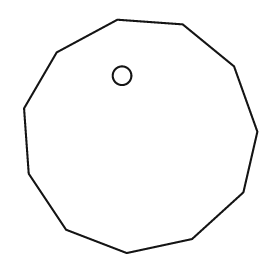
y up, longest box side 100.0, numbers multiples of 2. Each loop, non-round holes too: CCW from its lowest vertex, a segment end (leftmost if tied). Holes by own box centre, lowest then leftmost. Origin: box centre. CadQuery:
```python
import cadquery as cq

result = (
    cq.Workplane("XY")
    .moveTo(-6.0, -50.0)
    .lineTo(22.0, -44.0)
    .lineTo(44.0, -24.0)
    .lineTo(50.0, 2.0)
    .lineTo(40.0, 30.0)
    .lineTo(18.0, 48.0)
    .lineTo(-10.0, 50.0)
    .lineTo(-36.0, 36.0)
    .lineTo(-50.0, 12.0)
    .lineTo(-48.0, -16.0)
    .lineTo(-32.0, -40.0)
    .close()
    .moveTo(-8.0, 26.0)
    .circle(4.0)
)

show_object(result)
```